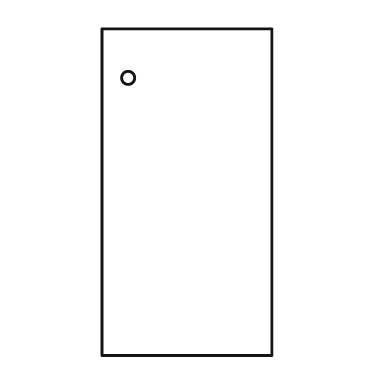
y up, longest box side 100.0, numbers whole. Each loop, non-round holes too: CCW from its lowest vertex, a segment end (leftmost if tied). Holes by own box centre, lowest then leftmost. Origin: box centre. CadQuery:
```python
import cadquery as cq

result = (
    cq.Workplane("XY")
    .moveTo(-26.0, -50.0)
    .lineTo(26.0, -50.0)
    .lineTo(26.0, 50.0)
    .lineTo(-26.0, 50.0)
    .close()
    .moveTo(-18.0, 35.0)
    .circle(2.0)
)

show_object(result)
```